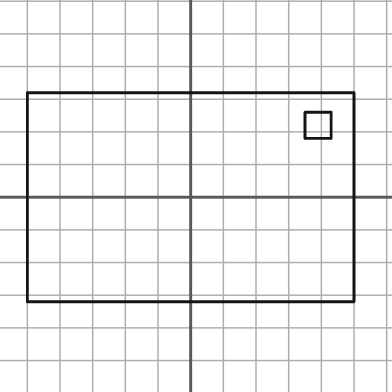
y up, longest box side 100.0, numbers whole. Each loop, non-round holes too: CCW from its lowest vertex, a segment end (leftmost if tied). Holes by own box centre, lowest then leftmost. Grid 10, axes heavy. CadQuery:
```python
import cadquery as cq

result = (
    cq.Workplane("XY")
    .moveTo(-50.0, -32.0)
    .lineTo(50.0, -32.0)
    .lineTo(50.0, 32.0)
    .lineTo(-50.0, 32.0)
    .close()
    .moveTo(35.0, 18.0)
    .lineTo(43.0, 18.0)
    .lineTo(43.0, 26.0)
    .lineTo(35.0, 26.0)
    .close()
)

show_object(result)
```